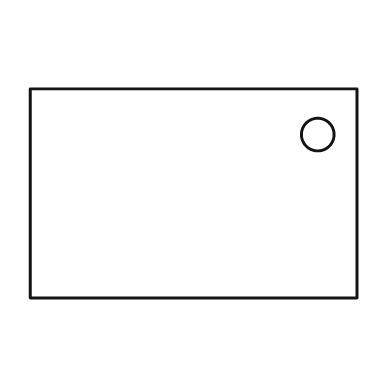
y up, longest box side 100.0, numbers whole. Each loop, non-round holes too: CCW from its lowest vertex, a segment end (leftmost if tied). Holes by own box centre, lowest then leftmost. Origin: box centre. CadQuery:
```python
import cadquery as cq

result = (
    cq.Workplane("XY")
    .moveTo(-50.0, -32.0)
    .lineTo(50.0, -32.0)
    .lineTo(50.0, 32.0)
    .lineTo(-50.0, 32.0)
    .close()
    .moveTo(38.0, 18.0)
    .circle(5.0)
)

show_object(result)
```